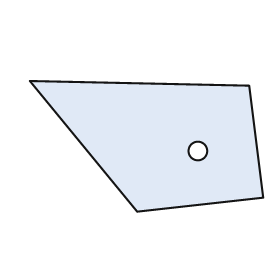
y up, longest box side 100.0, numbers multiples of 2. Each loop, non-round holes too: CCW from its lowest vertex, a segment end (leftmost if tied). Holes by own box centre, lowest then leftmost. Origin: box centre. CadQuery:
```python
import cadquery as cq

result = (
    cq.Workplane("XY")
    .moveTo(-4.0, -28.0)
    .lineTo(50.0, -22.0)
    .lineTo(44.0, 26.0)
    .lineTo(-50.0, 28.0)
    .close()
    .moveTo(22.0, -2.0)
    .circle(4.0)
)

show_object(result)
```